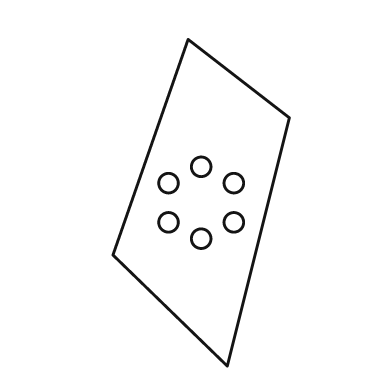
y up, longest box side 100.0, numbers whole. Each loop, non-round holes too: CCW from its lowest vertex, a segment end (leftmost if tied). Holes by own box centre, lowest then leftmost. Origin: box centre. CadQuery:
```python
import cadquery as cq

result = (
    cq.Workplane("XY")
    .moveTo(8.0, -50.0)
    .lineTo(27.0, 26.0)
    .lineTo(-4.0, 50.0)
    .lineTo(-27.0, -16.0)
    .close()
    .moveTo(0.0, -11.0)
    .circle(3.0)
    .moveTo(-10.0, -6.0)
    .circle(3.0)
    .moveTo(10.0, -6.0)
    .circle(3.0)
    .moveTo(-10.0, 6.0)
    .circle(3.0)
    .moveTo(10.0, 6.0)
    .circle(3.0)
    .moveTo(0.0, 11.0)
    .circle(3.0)
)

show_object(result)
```